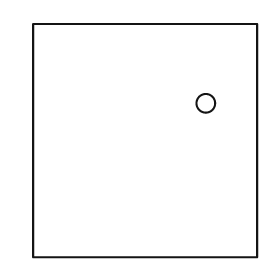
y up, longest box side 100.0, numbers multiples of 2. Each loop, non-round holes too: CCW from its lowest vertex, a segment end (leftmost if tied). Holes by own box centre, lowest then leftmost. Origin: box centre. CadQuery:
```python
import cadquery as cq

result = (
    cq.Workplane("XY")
    .moveTo(-48.0, -50.0)
    .lineTo(48.0, -50.0)
    .lineTo(48.0, 50.0)
    .lineTo(-48.0, 50.0)
    .close()
    .moveTo(26.0, 16.0)
    .circle(4.0)
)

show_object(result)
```